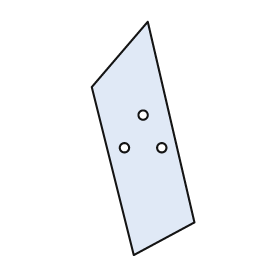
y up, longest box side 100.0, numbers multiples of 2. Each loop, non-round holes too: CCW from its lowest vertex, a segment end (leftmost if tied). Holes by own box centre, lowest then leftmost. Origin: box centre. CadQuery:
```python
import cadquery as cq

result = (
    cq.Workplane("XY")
    .moveTo(-4.0, -50.0)
    .lineTo(22.0, -36.0)
    .lineTo(2.0, 50.0)
    .lineTo(-22.0, 22.0)
    .close()
    .moveTo(-8.0, -4.0)
    .circle(2.0)
    .moveTo(8.0, -4.0)
    .circle(2.0)
    .moveTo(0.0, 10.0)
    .circle(2.0)
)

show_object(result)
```